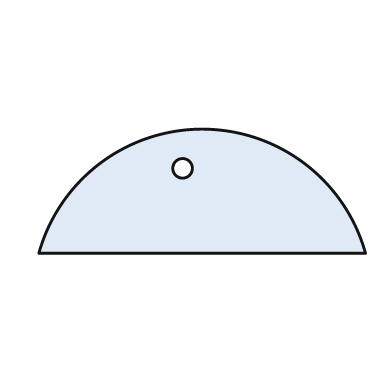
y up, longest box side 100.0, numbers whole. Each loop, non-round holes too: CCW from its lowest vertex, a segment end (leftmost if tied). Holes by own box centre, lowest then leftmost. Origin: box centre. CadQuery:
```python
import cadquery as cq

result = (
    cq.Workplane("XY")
    .moveTo(-50.0, -19.0)
    .lineTo(50.0, -19.0)
    .threePointArc((0.0, 19.0), (-50.0, -19.0))
    .close()
    .moveTo(-6.0, 7.0)
    .circle(3.0)
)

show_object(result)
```